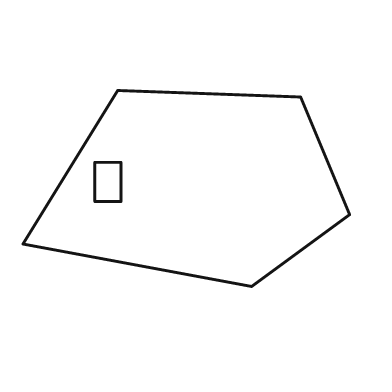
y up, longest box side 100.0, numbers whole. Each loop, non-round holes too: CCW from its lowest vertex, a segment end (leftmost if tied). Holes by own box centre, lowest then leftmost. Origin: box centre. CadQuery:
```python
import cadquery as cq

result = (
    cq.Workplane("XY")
    .moveTo(20.0, -30.0)
    .lineTo(50.0, -8.0)
    .lineTo(35.0, 28.0)
    .lineTo(-21.0, 30.0)
    .lineTo(-50.0, -17.0)
    .close()
    .moveTo(-28.0, -4.0)
    .lineTo(-20.0, -4.0)
    .lineTo(-20.0, 8.0)
    .lineTo(-28.0, 8.0)
    .close()
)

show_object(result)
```